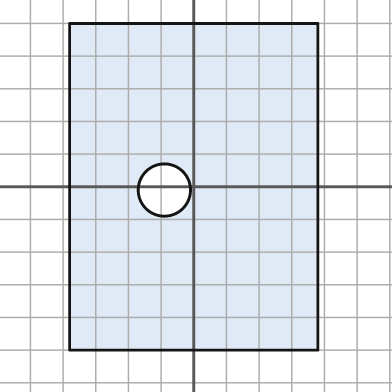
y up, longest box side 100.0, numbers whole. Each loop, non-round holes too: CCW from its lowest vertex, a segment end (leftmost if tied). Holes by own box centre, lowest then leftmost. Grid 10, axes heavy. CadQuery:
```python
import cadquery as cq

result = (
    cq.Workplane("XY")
    .moveTo(-38.0, -50.0)
    .lineTo(38.0, -50.0)
    .lineTo(38.0, 50.0)
    .lineTo(-38.0, 50.0)
    .close()
    .moveTo(-9.0, -1.0)
    .circle(8.0)
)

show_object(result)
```